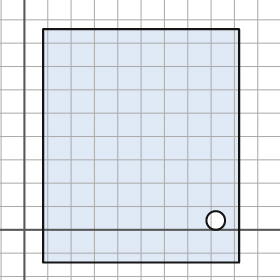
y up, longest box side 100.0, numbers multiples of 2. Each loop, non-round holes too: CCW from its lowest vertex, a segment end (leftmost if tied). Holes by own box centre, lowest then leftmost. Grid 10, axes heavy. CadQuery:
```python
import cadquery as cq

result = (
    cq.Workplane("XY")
    .moveTo(8.0, -14.0)
    .lineTo(92.0, -14.0)
    .lineTo(92.0, 86.0)
    .lineTo(8.0, 86.0)
    .close()
    .moveTo(82.0, 4.0)
    .circle(4.0)
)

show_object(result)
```